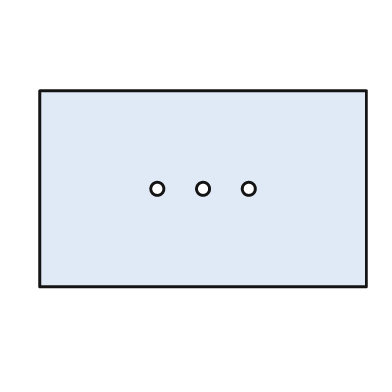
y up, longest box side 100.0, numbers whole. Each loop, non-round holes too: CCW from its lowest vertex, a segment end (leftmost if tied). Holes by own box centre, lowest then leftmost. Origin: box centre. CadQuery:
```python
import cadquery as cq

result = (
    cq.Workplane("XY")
    .moveTo(-50.0, -30.0)
    .lineTo(50.0, -30.0)
    .lineTo(50.0, 30.0)
    .lineTo(-50.0, 30.0)
    .close()
    .moveTo(-14.0, 0.0)
    .circle(2.0)
    .moveTo(0.0, 0.0)
    .circle(2.0)
    .moveTo(14.0, 0.0)
    .circle(2.0)
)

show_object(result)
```